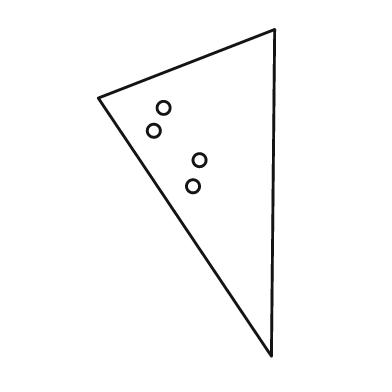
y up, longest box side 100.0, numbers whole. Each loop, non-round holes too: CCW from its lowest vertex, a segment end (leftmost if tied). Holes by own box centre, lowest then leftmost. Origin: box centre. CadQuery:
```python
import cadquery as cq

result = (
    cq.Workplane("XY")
    .moveTo(26.0, -50.0)
    .lineTo(27.0, 50.0)
    .lineTo(-27.0, 29.0)
    .close()
    .moveTo(2.0, 2.0)
    .circle(2.0)
    .moveTo(4.0, 10.0)
    .circle(2.0)
    .moveTo(-10.0, 19.0)
    .circle(2.0)
    .moveTo(-7.0, 26.0)
    .circle(2.0)
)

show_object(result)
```